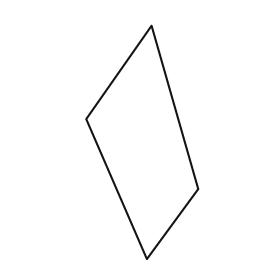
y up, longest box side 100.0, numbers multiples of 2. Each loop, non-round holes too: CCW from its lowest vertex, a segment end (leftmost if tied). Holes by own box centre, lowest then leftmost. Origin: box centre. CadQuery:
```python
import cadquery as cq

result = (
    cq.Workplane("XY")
    .moveTo(2.0, -50.0)
    .lineTo(24.0, -20.0)
    .lineTo(4.0, 50.0)
    .lineTo(-24.0, 10.0)
    .close()
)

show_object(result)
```